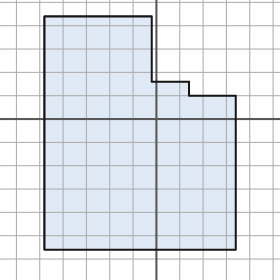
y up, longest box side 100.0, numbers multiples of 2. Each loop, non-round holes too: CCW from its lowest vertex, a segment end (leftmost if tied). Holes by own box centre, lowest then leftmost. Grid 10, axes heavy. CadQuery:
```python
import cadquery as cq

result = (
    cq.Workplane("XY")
    .moveTo(-48.0, -56.0)
    .lineTo(34.0, -56.0)
    .lineTo(34.0, 10.0)
    .lineTo(14.0, 10.0)
    .lineTo(14.0, 16.0)
    .lineTo(-2.0, 16.0)
    .lineTo(-2.0, 44.0)
    .lineTo(-48.0, 44.0)
    .close()
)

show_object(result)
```